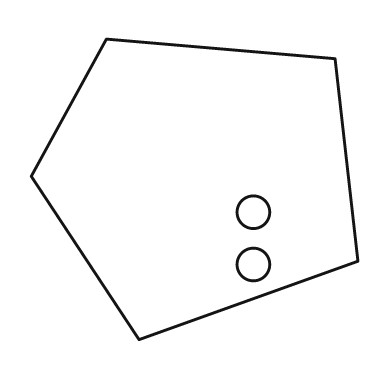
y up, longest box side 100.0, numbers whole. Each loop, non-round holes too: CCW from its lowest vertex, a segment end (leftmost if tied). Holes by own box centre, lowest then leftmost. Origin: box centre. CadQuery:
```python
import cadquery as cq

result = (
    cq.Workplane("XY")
    .moveTo(-17.0, -46.0)
    .lineTo(50.0, -22.0)
    .lineTo(43.0, 40.0)
    .lineTo(-27.0, 46.0)
    .lineTo(-50.0, 4.0)
    .close()
    .moveTo(18.0, -23.0)
    .circle(5.0)
    .moveTo(18.0, -7.0)
    .circle(5.0)
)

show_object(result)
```